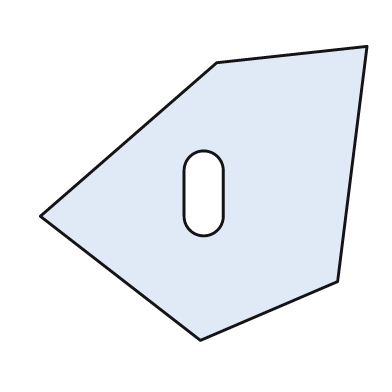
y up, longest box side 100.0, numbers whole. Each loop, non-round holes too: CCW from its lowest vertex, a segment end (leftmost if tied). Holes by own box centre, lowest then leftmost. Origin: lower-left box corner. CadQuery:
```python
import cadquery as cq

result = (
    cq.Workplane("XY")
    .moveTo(49.0, 0.0)
    .lineTo(91.0, 18.0)
    .lineTo(100.0, 90.0)
    .lineTo(54.0, 85.0)
    .lineTo(0.0, 38.0)
    .close()
    .moveTo(44.0, 38.0)
    .threePointArc((50.0, 32.0), (56.0, 38.0))
    .lineTo(56.0, 52.0)
    .threePointArc((50.0, 58.0), (44.0, 52.0))
    .close()
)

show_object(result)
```